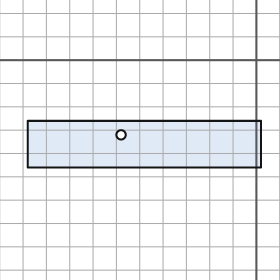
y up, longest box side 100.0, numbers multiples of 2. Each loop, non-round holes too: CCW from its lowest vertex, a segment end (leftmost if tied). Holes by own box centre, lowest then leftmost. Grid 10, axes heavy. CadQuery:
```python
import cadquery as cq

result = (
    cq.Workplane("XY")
    .moveTo(-98.0, -46.0)
    .lineTo(2.0, -46.0)
    .lineTo(2.0, -26.0)
    .lineTo(-98.0, -26.0)
    .close()
    .moveTo(-58.0, -32.0)
    .circle(2.0)
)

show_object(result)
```